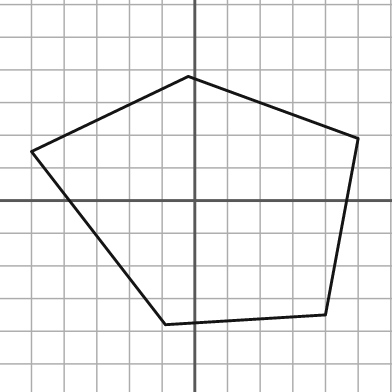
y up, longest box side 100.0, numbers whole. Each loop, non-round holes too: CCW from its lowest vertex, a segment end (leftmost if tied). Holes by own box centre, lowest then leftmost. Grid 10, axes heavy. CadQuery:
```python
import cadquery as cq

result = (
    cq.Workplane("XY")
    .moveTo(-9.0, -38.0)
    .lineTo(40.0, -35.0)
    .lineTo(50.0, 19.0)
    .lineTo(-2.0, 38.0)
    .lineTo(-50.0, 15.0)
    .close()
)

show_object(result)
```